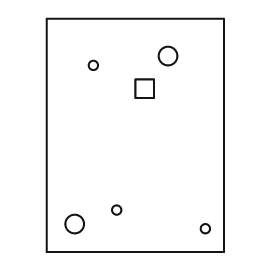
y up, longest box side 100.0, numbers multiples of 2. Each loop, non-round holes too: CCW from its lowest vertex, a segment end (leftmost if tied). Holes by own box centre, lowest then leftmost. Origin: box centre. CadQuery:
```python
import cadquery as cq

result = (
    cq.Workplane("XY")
    .moveTo(-38.0, -50.0)
    .lineTo(38.0, -50.0)
    .lineTo(38.0, 50.0)
    .lineTo(-38.0, 50.0)
    .close()
    .moveTo(30.0, -40.0)
    .circle(2.0)
    .moveTo(-26.0, -38.0)
    .circle(4.0)
    .moveTo(-8.0, -32.0)
    .circle(2.0)
    .moveTo(0.0, 16.0)
    .lineTo(8.0, 16.0)
    .lineTo(8.0, 24.0)
    .lineTo(0.0, 24.0)
    .close()
    .moveTo(-18.0, 30.0)
    .circle(2.0)
    .moveTo(14.0, 34.0)
    .circle(4.0)
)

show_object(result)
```